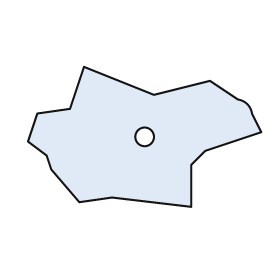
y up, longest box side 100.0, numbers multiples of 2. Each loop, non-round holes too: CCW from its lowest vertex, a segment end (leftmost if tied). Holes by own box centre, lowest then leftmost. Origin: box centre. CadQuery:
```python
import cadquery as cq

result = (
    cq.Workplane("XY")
    .moveTo(20.0, -30.0)
    .lineTo(20.0, -12.0)
    .lineTo(26.0, -6.0)
    .lineTo(50.0, 2.0)
    .lineTo(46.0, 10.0)
    .threePointArc((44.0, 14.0), (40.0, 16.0))
    .lineTo(28.0, 24.0)
    .lineTo(4.0, 18.0)
    .lineTo(-26.0, 30.0)
    .lineTo(-32.0, 12.0)
    .lineTo(-46.0, 10.0)
    .lineTo(-50.0, -2.0)
    .lineTo(-42.0, -8.0)
    .lineTo(-40.0, -14.0)
    .lineTo(-28.0, -28.0)
    .lineTo(-14.0, -26.0)
    .close()
    .moveTo(0.0, 0.0)
    .circle(4.0)
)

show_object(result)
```